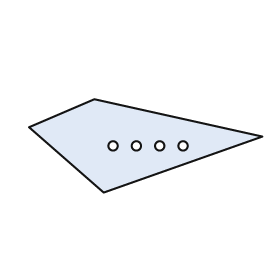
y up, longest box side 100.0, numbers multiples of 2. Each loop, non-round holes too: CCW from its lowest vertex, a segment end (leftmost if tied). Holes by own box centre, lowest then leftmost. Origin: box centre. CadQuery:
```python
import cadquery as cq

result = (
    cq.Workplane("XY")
    .moveTo(-18.0, -20.0)
    .lineTo(50.0, 4.0)
    .lineTo(-22.0, 20.0)
    .lineTo(-50.0, 8.0)
    .close()
    .moveTo(-14.0, 0.0)
    .circle(2.0)
    .moveTo(-4.0, 0.0)
    .circle(2.0)
    .moveTo(6.0, 0.0)
    .circle(2.0)
    .moveTo(16.0, 0.0)
    .circle(2.0)
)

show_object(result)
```